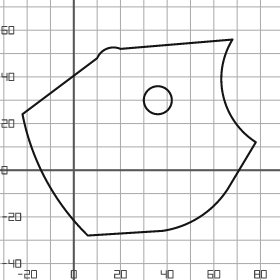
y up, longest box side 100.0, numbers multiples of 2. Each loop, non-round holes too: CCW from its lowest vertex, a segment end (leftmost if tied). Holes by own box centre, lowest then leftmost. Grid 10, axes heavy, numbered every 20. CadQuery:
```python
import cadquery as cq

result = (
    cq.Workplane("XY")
    .moveTo(6.0, -28.0)
    .lineTo(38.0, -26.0)
    .threePointArc((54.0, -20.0), (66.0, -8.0))
    .lineTo(78.0, 12.0)
    .threePointArc((64.0, 32.0), (68.0, 56.0))
    .lineTo(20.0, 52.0)
    .threePointArc((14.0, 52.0), (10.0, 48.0))
    .lineTo(-22.0, 24.0)
    .threePointArc((-12.0, -4.0), (6.0, -28.0))
    .close()
    .moveTo(36.0, 30.0)
    .circle(6.0)
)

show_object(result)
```